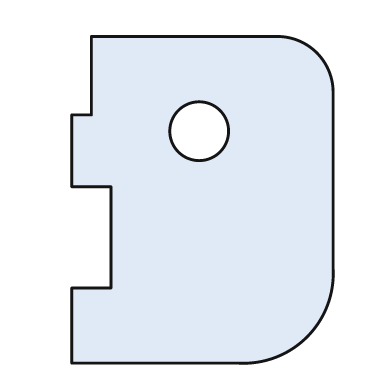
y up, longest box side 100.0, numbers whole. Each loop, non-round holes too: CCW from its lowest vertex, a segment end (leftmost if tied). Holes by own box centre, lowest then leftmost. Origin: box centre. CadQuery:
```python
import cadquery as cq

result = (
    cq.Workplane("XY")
    .moveTo(-40.0, -50.0)
    .lineTo(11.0, -50.0)
    .threePointArc((32.0, -42.0), (40.0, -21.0))
    .lineTo(40.0, 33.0)
    .threePointArc((35.0, 45.0), (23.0, 50.0))
    .lineTo(-34.0, 50.0)
    .lineTo(-34.0, 26.0)
    .lineTo(-40.0, 26.0)
    .lineTo(-40.0, 4.0)
    .lineTo(-28.0, 4.0)
    .lineTo(-28.0, -27.0)
    .lineTo(-40.0, -27.0)
    .close()
    .moveTo(-1.0, 21.0)
    .circle(9.0)
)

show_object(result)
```